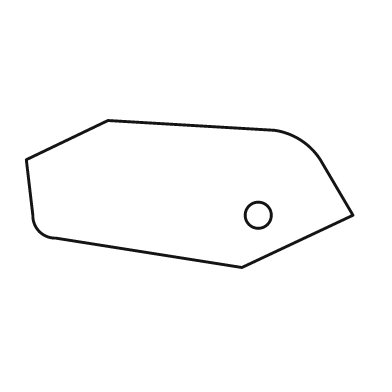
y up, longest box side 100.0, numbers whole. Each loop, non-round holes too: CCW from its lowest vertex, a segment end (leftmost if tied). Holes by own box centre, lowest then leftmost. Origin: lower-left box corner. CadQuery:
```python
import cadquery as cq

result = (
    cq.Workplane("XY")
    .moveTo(66.0, 0.0)
    .lineTo(100.0, 16.0)
    .lineTo(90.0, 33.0)
    .threePointArc((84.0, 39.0), (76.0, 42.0))
    .lineTo(25.0, 45.0)
    .lineTo(0.0, 33.0)
    .lineTo(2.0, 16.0)
    .threePointArc((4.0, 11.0), (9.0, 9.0))
    .close()
    .moveTo(71.0, 16.0)
    .circle(4.0)
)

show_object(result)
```